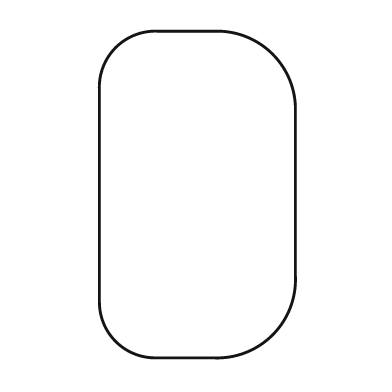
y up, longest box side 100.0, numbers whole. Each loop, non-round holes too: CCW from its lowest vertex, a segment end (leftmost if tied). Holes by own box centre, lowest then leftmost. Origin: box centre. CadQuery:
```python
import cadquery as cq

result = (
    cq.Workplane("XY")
    .moveTo(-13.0, -50.0)
    .lineTo(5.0, -50.0)
    .threePointArc((23.0, -43.0), (30.0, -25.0))
    .lineTo(30.0, 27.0)
    .threePointArc((23.0, 43.0), (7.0, 50.0))
    .lineTo(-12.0, 50.0)
    .threePointArc((-25.0, 45.0), (-30.0, 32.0))
    .lineTo(-30.0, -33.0)
    .threePointArc((-25.0, -45.0), (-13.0, -50.0))
    .close()
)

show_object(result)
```